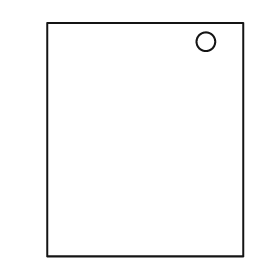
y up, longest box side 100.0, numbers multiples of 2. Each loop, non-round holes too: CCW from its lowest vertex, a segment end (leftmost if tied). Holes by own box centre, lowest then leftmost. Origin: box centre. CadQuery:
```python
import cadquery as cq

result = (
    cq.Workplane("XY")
    .moveTo(-42.0, -50.0)
    .lineTo(42.0, -50.0)
    .lineTo(42.0, 50.0)
    .lineTo(-42.0, 50.0)
    .close()
    .moveTo(26.0, 42.0)
    .circle(4.0)
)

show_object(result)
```